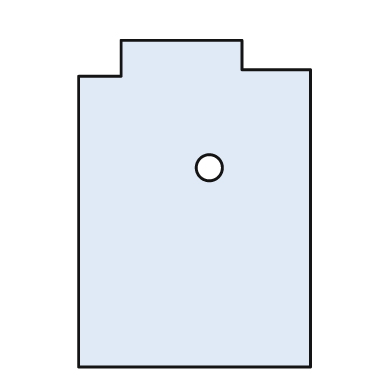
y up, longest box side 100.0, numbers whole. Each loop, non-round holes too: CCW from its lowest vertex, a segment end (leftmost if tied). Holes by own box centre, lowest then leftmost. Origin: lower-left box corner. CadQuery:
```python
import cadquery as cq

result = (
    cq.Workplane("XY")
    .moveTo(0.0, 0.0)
    .lineTo(71.0, 0.0)
    .lineTo(71.0, 91.0)
    .lineTo(50.0, 91.0)
    .lineTo(50.0, 100.0)
    .lineTo(13.0, 100.0)
    .lineTo(13.0, 89.0)
    .lineTo(0.0, 89.0)
    .close()
    .moveTo(40.0, 61.0)
    .circle(4.0)
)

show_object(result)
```